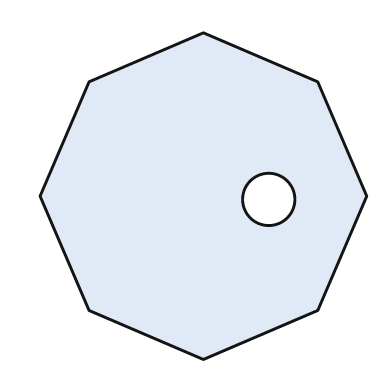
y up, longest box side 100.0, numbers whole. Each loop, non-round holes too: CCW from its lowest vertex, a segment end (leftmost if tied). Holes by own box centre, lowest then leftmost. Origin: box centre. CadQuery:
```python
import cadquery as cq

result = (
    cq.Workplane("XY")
    .moveTo(0.0, -50.0)
    .lineTo(35.0, -35.0)
    .lineTo(50.0, 0.0)
    .lineTo(35.0, 35.0)
    .lineTo(0.0, 50.0)
    .lineTo(-35.0, 35.0)
    .lineTo(-50.0, 0.0)
    .lineTo(-35.0, -35.0)
    .close()
    .moveTo(20.0, -1.0)
    .circle(8.0)
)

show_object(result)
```